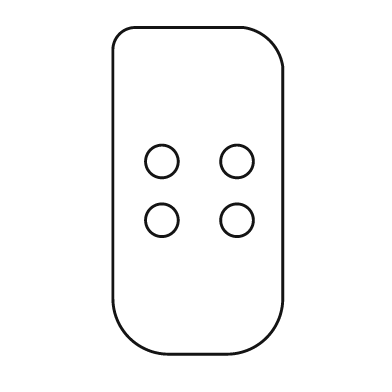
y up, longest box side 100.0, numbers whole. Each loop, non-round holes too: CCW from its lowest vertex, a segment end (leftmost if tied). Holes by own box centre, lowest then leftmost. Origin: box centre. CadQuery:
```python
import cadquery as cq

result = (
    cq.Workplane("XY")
    .moveTo(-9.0, -50.0)
    .lineTo(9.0, -50.0)
    .threePointArc((21.0, -45.0), (26.0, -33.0))
    .lineTo(26.0, 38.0)
    .threePointArc((22.0, 46.0), (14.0, 50.0))
    .lineTo(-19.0, 50.0)
    .threePointArc((-24.0, 48.0), (-26.0, 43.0))
    .lineTo(-26.0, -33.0)
    .threePointArc((-21.0, -45.0), (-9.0, -50.0))
    .close()
    .moveTo(-11.0, -9.0)
    .circle(5.0)
    .moveTo(12.0, -9.0)
    .circle(5.0)
    .moveTo(-11.0, 9.0)
    .circle(5.0)
    .moveTo(12.0, 9.0)
    .circle(5.0)
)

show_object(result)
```